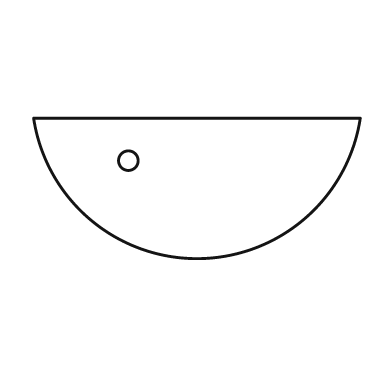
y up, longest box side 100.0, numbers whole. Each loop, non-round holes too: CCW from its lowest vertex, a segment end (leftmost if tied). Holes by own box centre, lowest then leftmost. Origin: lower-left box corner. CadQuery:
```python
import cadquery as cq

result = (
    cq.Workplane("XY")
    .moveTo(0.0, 43.0)
    .threePointArc((50.0, 0.0), (100.0, 43.0))
    .close()
    .moveTo(29.0, 30.0)
    .circle(3.0)
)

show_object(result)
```